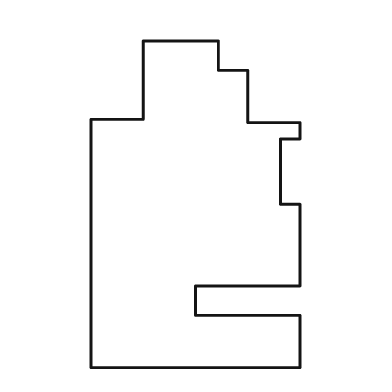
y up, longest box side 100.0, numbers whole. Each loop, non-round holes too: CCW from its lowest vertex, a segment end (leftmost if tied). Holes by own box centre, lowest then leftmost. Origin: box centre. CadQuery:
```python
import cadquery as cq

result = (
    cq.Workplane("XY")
    .moveTo(-32.0, -50.0)
    .lineTo(32.0, -50.0)
    .lineTo(32.0, -34.0)
    .lineTo(0.0, -34.0)
    .lineTo(0.0, -25.0)
    .lineTo(32.0, -25.0)
    .lineTo(32.0, 0.0)
    .lineTo(26.0, 0.0)
    .lineTo(26.0, 20.0)
    .lineTo(32.0, 20.0)
    .lineTo(32.0, 25.0)
    .lineTo(16.0, 25.0)
    .lineTo(16.0, 41.0)
    .lineTo(7.0, 41.0)
    .lineTo(7.0, 50.0)
    .lineTo(-16.0, 50.0)
    .lineTo(-16.0, 26.0)
    .lineTo(-32.0, 26.0)
    .close()
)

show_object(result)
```